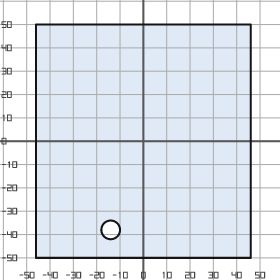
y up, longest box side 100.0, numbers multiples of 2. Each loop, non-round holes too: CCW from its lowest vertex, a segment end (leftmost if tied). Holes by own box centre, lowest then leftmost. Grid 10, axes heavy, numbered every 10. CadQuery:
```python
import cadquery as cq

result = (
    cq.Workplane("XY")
    .moveTo(-46.0, -50.0)
    .lineTo(46.0, -50.0)
    .lineTo(46.0, 50.0)
    .lineTo(-46.0, 50.0)
    .close()
    .moveTo(-14.0, -38.0)
    .circle(4.0)
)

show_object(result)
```